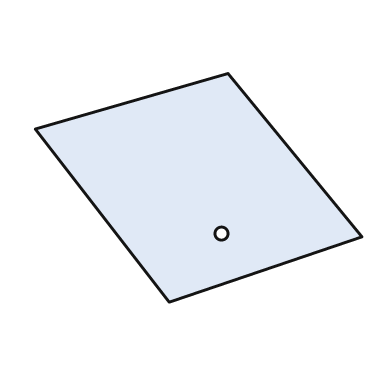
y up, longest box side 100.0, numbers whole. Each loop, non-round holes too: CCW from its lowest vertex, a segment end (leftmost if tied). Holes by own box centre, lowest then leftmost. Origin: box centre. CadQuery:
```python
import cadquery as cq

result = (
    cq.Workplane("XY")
    .moveTo(-9.0, -35.0)
    .lineTo(50.0, -15.0)
    .lineTo(9.0, 35.0)
    .lineTo(-50.0, 18.0)
    .close()
    .moveTo(7.0, -14.0)
    .circle(2.0)
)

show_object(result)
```